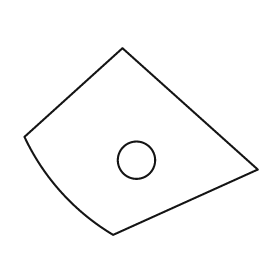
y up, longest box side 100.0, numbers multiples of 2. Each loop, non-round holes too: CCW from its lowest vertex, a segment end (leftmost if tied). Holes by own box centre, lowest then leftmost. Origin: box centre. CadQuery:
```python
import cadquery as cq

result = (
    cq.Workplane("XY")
    .moveTo(-12.0, -40.0)
    .lineTo(50.0, -12.0)
    .lineTo(-8.0, 40.0)
    .lineTo(-50.0, 2.0)
    .threePointArc((-34.0, -22.0), (-12.0, -40.0))
    .close()
    .moveTo(-2.0, -8.0)
    .circle(8.0)
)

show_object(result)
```